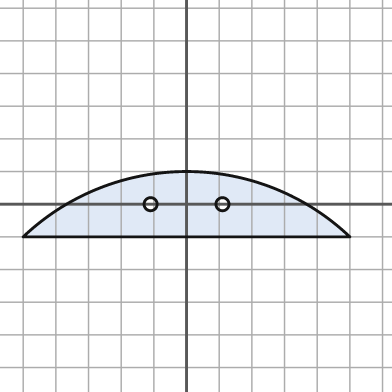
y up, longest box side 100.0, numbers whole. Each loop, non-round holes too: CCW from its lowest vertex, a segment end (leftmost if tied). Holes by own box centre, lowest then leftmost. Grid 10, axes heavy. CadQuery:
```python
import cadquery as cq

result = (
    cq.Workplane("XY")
    .moveTo(-50.0, -10.0)
    .lineTo(50.0, -10.0)
    .threePointArc((0.0, 10.0), (-50.0, -10.0))
    .close()
    .moveTo(-11.0, 0.0)
    .circle(2.0)
    .moveTo(11.0, 0.0)
    .circle(2.0)
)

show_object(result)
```